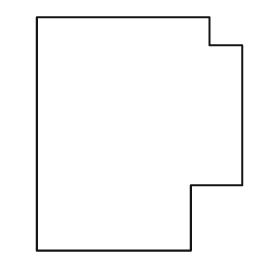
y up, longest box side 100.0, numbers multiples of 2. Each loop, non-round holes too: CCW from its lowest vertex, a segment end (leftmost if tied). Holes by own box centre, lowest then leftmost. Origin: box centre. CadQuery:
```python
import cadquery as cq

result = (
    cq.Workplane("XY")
    .moveTo(-44.0, -50.0)
    .lineTo(22.0, -50.0)
    .lineTo(22.0, -22.0)
    .lineTo(44.0, -22.0)
    .lineTo(44.0, 38.0)
    .lineTo(30.0, 38.0)
    .lineTo(30.0, 50.0)
    .lineTo(-44.0, 50.0)
    .close()
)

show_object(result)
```